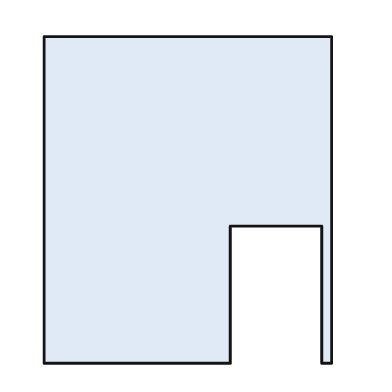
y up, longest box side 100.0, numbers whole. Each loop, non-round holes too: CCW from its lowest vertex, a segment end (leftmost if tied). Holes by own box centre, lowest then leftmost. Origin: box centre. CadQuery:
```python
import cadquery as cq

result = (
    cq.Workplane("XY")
    .moveTo(-44.0, -50.0)
    .lineTo(13.0, -50.0)
    .lineTo(13.0, -8.0)
    .lineTo(41.0, -8.0)
    .lineTo(41.0, -50.0)
    .lineTo(44.0, -50.0)
    .lineTo(44.0, 50.0)
    .lineTo(-44.0, 50.0)
    .close()
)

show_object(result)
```